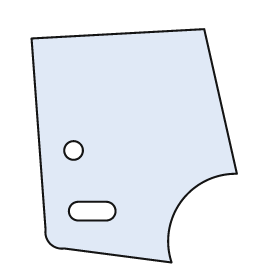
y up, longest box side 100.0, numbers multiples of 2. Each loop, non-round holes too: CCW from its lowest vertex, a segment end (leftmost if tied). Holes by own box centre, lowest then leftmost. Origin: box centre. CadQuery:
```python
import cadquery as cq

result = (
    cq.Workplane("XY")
    .moveTo(16.0, -50.0)
    .threePointArc((20.0, -24.0), (44.0, -12.0))
    .lineTo(30.0, 50.0)
    .lineTo(-44.0, 46.0)
    .lineTo(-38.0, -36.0)
    .threePointArc((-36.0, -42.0), (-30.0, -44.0))
    .close()
    .moveTo(-24.0, -32.0)
    .lineTo(-12.0, -32.0)
    .threePointArc((-8.0, -28.0), (-12.0, -24.0))
    .lineTo(-24.0, -24.0)
    .threePointArc((-28.0, -28.0), (-24.0, -32.0))
    .close()
    .moveTo(-26.0, -2.0)
    .circle(4.0)
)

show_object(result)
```